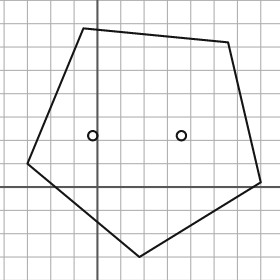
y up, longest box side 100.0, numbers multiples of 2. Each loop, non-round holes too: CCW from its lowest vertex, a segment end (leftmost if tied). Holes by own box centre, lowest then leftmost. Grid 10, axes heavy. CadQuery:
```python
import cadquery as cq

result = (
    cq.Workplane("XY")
    .moveTo(18.0, -30.0)
    .lineTo(70.0, 2.0)
    .lineTo(56.0, 62.0)
    .lineTo(-6.0, 68.0)
    .lineTo(-30.0, 10.0)
    .close()
    .moveTo(-2.0, 22.0)
    .circle(2.0)
    .moveTo(36.0, 22.0)
    .circle(2.0)
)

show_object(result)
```